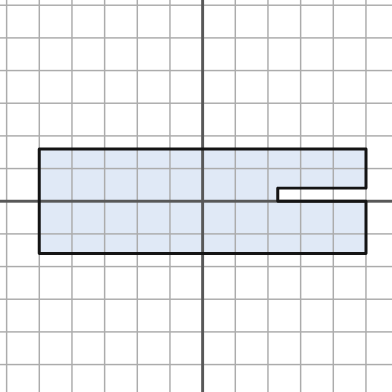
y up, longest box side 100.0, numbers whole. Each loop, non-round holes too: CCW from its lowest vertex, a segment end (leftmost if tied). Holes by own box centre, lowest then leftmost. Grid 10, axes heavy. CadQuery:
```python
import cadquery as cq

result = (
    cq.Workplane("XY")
    .moveTo(-50.0, -16.0)
    .lineTo(50.0, -16.0)
    .lineTo(50.0, 0.0)
    .lineTo(23.0, 0.0)
    .lineTo(23.0, 4.0)
    .lineTo(50.0, 4.0)
    .lineTo(50.0, 16.0)
    .lineTo(-50.0, 16.0)
    .close()
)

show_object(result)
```